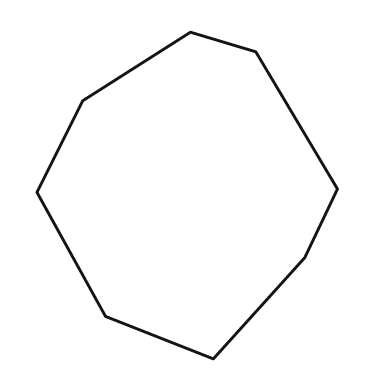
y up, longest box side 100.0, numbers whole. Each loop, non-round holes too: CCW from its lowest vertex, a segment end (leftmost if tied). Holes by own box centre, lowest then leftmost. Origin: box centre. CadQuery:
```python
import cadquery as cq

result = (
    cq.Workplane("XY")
    .moveTo(8.0, -50.0)
    .lineTo(36.0, -19.0)
    .lineTo(46.0, 2.0)
    .lineTo(21.0, 44.0)
    .lineTo(1.0, 50.0)
    .lineTo(-32.0, 29.0)
    .lineTo(-46.0, 1.0)
    .lineTo(-25.0, -37.0)
    .close()
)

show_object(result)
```